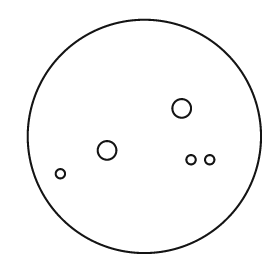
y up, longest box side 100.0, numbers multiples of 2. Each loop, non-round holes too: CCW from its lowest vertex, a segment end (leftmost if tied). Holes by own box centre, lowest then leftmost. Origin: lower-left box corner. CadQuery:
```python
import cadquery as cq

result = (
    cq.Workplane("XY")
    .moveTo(50.0, 50.0)
    .circle(50.0)
    .moveTo(14.0, 34.0)
    .circle(2.0)
    .moveTo(70.0, 40.0)
    .circle(2.0)
    .moveTo(78.0, 40.0)
    .circle(2.0)
    .moveTo(34.0, 44.0)
    .circle(4.0)
    .moveTo(66.0, 62.0)
    .circle(4.0)
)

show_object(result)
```